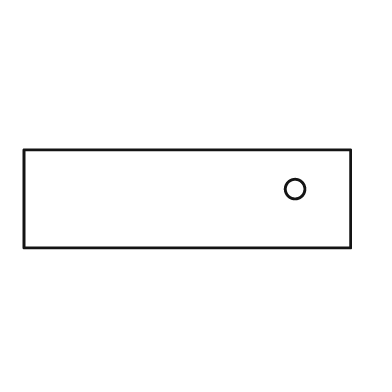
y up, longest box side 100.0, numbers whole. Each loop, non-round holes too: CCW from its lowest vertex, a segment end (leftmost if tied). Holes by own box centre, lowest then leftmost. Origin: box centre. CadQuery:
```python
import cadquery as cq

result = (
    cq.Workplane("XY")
    .moveTo(-50.0, -15.0)
    .lineTo(50.0, -15.0)
    .lineTo(50.0, 15.0)
    .lineTo(-50.0, 15.0)
    .close()
    .moveTo(33.0, 3.0)
    .circle(3.0)
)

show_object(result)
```